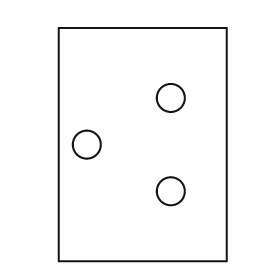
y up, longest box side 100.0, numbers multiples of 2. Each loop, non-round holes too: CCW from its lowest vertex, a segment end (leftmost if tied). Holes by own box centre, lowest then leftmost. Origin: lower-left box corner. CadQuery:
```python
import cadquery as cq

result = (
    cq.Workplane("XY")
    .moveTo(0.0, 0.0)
    .lineTo(72.0, 0.0)
    .lineTo(72.0, 100.0)
    .lineTo(0.0, 100.0)
    .close()
    .moveTo(48.0, 30.0)
    .circle(6.0)
    .moveTo(12.0, 50.0)
    .circle(6.0)
    .moveTo(48.0, 70.0)
    .circle(6.0)
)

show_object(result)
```